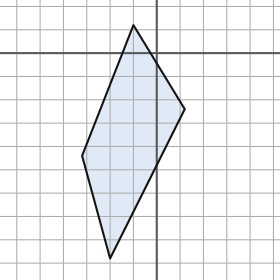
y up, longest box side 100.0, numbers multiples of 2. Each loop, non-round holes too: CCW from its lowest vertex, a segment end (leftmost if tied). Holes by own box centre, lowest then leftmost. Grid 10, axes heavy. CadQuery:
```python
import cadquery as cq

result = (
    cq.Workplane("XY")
    .moveTo(-20.0, -88.0)
    .lineTo(12.0, -24.0)
    .lineTo(-10.0, 12.0)
    .lineTo(-32.0, -44.0)
    .close()
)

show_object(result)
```